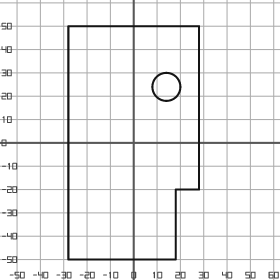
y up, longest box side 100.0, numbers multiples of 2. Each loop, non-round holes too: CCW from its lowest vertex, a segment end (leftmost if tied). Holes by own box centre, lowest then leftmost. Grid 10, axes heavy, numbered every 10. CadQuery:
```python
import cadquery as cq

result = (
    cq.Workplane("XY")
    .moveTo(-28.0, -50.0)
    .lineTo(18.0, -50.0)
    .lineTo(18.0, -20.0)
    .lineTo(28.0, -20.0)
    .lineTo(28.0, 50.0)
    .lineTo(-28.0, 50.0)
    .close()
    .moveTo(14.0, 24.0)
    .circle(6.0)
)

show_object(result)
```